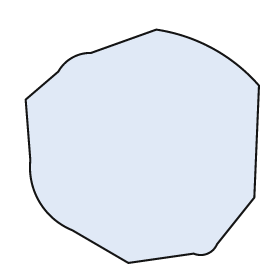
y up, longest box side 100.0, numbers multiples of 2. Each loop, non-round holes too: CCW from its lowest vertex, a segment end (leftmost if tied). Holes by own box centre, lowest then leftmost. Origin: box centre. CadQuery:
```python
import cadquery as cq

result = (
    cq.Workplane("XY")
    .moveTo(-6.0, -50.0)
    .lineTo(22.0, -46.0)
    .threePointArc((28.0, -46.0), (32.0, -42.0))
    .lineTo(48.0, -22.0)
    .lineTo(50.0, 26.0)
    .threePointArc((30.0, 42.0), (6.0, 50.0))
    .lineTo(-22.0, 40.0)
    .threePointArc((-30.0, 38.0), (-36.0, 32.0))
    .lineTo(-50.0, 20.0)
    .lineTo(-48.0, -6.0)
    .threePointArc((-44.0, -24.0), (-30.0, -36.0))
    .close()
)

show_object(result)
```